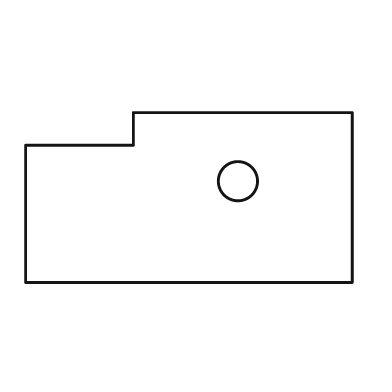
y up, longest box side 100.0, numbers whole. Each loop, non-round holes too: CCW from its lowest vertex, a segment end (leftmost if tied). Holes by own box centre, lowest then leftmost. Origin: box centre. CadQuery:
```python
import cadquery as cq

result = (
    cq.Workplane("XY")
    .moveTo(-50.0, -26.0)
    .lineTo(50.0, -26.0)
    .lineTo(50.0, 26.0)
    .lineTo(-17.0, 26.0)
    .lineTo(-17.0, 16.0)
    .lineTo(-50.0, 16.0)
    .close()
    .moveTo(15.0, 5.0)
    .circle(6.0)
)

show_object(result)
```